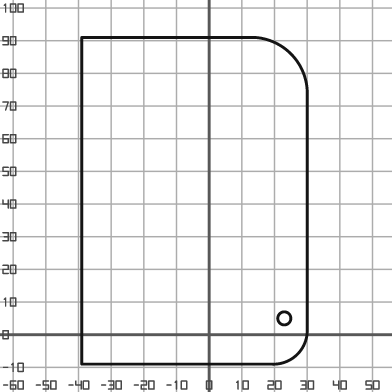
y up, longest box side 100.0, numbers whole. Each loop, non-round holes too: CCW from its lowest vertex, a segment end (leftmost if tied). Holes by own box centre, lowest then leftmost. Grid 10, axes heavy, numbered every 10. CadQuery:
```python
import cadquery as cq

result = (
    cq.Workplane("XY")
    .moveTo(-39.0, -9.0)
    .lineTo(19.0, -9.0)
    .threePointArc((27.0, -6.0), (30.0, 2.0))
    .lineTo(30.0, 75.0)
    .threePointArc((25.0, 86.0), (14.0, 91.0))
    .lineTo(-39.0, 91.0)
    .close()
    .moveTo(23.0, 5.0)
    .circle(2.0)
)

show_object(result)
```